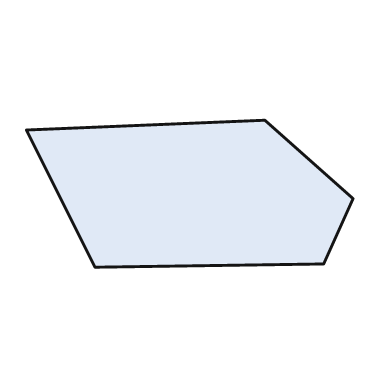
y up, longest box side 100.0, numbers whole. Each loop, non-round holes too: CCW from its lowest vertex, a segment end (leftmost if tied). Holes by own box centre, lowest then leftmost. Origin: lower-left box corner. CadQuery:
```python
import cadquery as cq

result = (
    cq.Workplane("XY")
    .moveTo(21.0, 0.0)
    .lineTo(91.0, 1.0)
    .lineTo(100.0, 21.0)
    .lineTo(73.0, 45.0)
    .lineTo(0.0, 42.0)
    .close()
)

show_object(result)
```